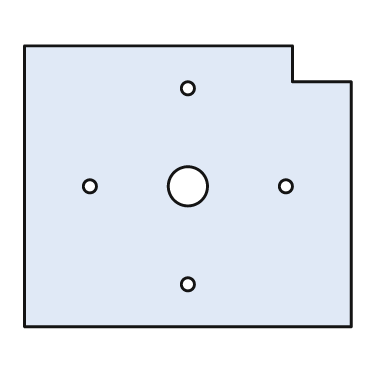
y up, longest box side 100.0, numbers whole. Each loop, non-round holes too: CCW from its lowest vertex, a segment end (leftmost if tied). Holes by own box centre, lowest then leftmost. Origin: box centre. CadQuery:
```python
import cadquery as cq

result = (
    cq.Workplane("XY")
    .moveTo(-50.0, -43.0)
    .lineTo(50.0, -43.0)
    .lineTo(50.0, 32.0)
    .lineTo(32.0, 32.0)
    .lineTo(32.0, 43.0)
    .lineTo(-50.0, 43.0)
    .close()
    .moveTo(0.0, -30.0)
    .circle(2.0)
    .moveTo(-30.0, 0.0)
    .circle(2.0)
    .moveTo(0.0, 0.0)
    .circle(6.0)
    .moveTo(30.0, 0.0)
    .circle(2.0)
    .moveTo(0.0, 30.0)
    .circle(2.0)
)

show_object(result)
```